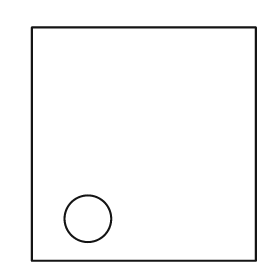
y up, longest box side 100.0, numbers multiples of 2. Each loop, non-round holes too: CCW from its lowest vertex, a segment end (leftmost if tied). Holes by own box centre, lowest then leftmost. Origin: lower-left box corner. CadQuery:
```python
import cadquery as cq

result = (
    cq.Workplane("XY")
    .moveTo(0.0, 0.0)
    .lineTo(96.0, 0.0)
    .lineTo(96.0, 100.0)
    .lineTo(0.0, 100.0)
    .close()
    .moveTo(24.0, 18.0)
    .circle(10.0)
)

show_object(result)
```